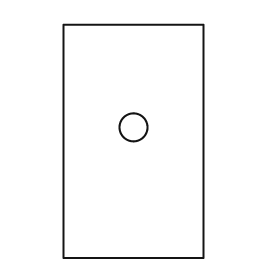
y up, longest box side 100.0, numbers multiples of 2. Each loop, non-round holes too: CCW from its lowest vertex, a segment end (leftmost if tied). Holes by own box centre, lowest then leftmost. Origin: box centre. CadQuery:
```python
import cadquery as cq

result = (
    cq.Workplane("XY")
    .moveTo(-30.0, -50.0)
    .lineTo(30.0, -50.0)
    .lineTo(30.0, 50.0)
    .lineTo(-30.0, 50.0)
    .close()
    .moveTo(0.0, 6.0)
    .circle(6.0)
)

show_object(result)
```